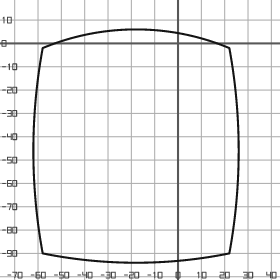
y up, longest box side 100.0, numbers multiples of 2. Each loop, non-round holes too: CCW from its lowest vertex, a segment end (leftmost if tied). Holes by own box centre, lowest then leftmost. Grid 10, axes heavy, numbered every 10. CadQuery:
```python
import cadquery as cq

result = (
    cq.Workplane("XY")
    .moveTo(-58.0, -90.0)
    .threePointArc((-18.0, -94.0), (22.0, -90.0))
    .threePointArc((26.0, -46.0), (22.0, -2.0))
    .threePointArc((-18.0, 6.0), (-58.0, -2.0))
    .threePointArc((-62.0, -46.0), (-58.0, -90.0))
    .close()
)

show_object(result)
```